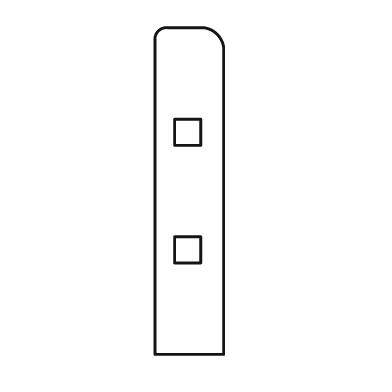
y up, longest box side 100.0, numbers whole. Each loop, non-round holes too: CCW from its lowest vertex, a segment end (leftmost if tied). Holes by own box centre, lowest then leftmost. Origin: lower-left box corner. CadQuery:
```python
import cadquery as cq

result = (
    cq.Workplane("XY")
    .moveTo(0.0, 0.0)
    .lineTo(21.0, 0.0)
    .lineTo(21.0, 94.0)
    .threePointArc((19.0, 98.0), (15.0, 100.0))
    .lineTo(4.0, 100.0)
    .threePointArc((1.0, 99.0), (0.0, 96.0))
    .close()
    .moveTo(6.0, 28.0)
    .lineTo(14.0, 28.0)
    .lineTo(14.0, 36.0)
    .lineTo(6.0, 36.0)
    .close()
    .moveTo(6.0, 64.0)
    .lineTo(14.0, 64.0)
    .lineTo(14.0, 72.0)
    .lineTo(6.0, 72.0)
    .close()
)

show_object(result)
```